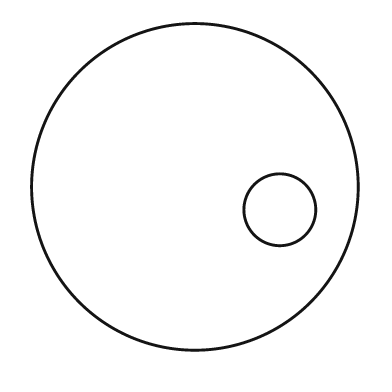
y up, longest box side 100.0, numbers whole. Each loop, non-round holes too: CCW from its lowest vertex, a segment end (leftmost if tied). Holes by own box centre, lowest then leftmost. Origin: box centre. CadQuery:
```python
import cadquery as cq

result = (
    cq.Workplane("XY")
    .moveTo(0.0, 0.0)
    .circle(50.0)
    .moveTo(26.0, -7.0)
    .circle(11.0)
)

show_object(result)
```